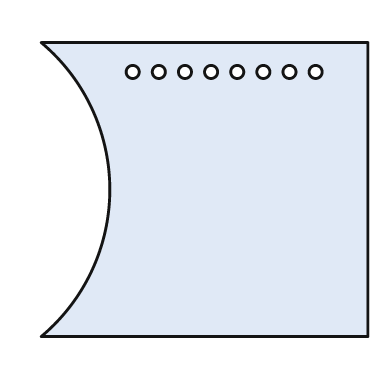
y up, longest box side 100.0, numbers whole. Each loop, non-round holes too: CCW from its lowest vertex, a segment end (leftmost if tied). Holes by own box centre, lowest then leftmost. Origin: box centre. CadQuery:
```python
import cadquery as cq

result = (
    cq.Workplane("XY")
    .moveTo(-50.0, -45.0)
    .lineTo(50.0, -45.0)
    .lineTo(50.0, 45.0)
    .lineTo(-50.0, 45.0)
    .threePointArc((-29.0, 0.0), (-50.0, -45.0))
    .close()
    .moveTo(-22.0, 36.0)
    .circle(2.0)
    .moveTo(-14.0, 36.0)
    .circle(2.0)
    .moveTo(-6.0, 36.0)
    .circle(2.0)
    .moveTo(2.0, 36.0)
    .circle(2.0)
    .moveTo(10.0, 36.0)
    .circle(2.0)
    .moveTo(18.0, 36.0)
    .circle(2.0)
    .moveTo(26.0, 36.0)
    .circle(2.0)
    .moveTo(34.0, 36.0)
    .circle(2.0)
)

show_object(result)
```